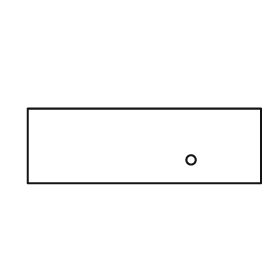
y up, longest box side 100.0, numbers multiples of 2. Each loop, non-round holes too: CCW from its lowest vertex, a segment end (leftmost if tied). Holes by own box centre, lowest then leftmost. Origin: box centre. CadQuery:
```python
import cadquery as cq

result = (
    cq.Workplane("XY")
    .moveTo(-50.0, -16.0)
    .lineTo(50.0, -16.0)
    .lineTo(50.0, 16.0)
    .lineTo(-50.0, 16.0)
    .close()
    .moveTo(20.0, -6.0)
    .circle(2.0)
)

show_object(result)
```